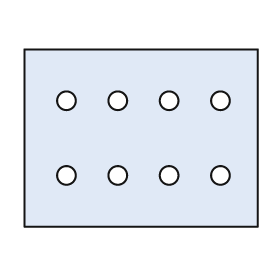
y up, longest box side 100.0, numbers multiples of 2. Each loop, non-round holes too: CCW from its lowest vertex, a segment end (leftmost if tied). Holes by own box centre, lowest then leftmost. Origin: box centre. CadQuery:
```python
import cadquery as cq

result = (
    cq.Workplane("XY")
    .moveTo(-50.0, -38.0)
    .lineTo(50.0, -38.0)
    .lineTo(50.0, 38.0)
    .lineTo(-50.0, 38.0)
    .close()
    .moveTo(-32.0, -16.0)
    .circle(4.0)
    .moveTo(-10.0, -16.0)
    .circle(4.0)
    .moveTo(12.0, -16.0)
    .circle(4.0)
    .moveTo(34.0, -16.0)
    .circle(4.0)
    .moveTo(-32.0, 16.0)
    .circle(4.0)
    .moveTo(-10.0, 16.0)
    .circle(4.0)
    .moveTo(12.0, 16.0)
    .circle(4.0)
    .moveTo(34.0, 16.0)
    .circle(4.0)
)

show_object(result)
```